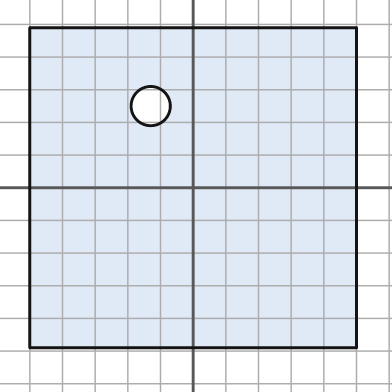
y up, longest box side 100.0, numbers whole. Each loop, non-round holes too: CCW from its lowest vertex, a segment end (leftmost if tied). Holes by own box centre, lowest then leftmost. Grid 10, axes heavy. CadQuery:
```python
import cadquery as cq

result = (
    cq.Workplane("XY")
    .moveTo(-50.0, -49.0)
    .lineTo(50.0, -49.0)
    .lineTo(50.0, 49.0)
    .lineTo(-50.0, 49.0)
    .close()
    .moveTo(-13.0, 25.0)
    .circle(6.0)
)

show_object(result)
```